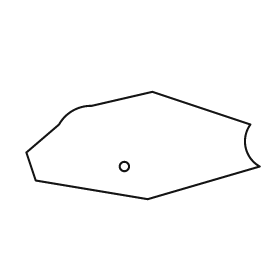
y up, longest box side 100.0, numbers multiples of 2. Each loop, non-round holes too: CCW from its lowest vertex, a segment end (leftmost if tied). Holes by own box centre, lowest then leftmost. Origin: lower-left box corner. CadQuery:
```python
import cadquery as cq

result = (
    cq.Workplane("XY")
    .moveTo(52.0, 0.0)
    .lineTo(100.0, 14.0)
    .threePointArc((94.0, 22.0), (96.0, 32.0))
    .lineTo(54.0, 46.0)
    .lineTo(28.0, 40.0)
    .threePointArc((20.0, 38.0), (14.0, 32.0))
    .lineTo(0.0, 20.0)
    .lineTo(4.0, 8.0)
    .close()
    .moveTo(42.0, 14.0)
    .circle(2.0)
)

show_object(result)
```